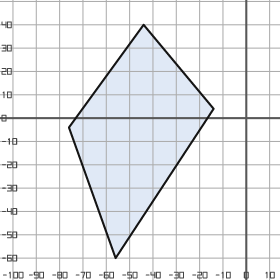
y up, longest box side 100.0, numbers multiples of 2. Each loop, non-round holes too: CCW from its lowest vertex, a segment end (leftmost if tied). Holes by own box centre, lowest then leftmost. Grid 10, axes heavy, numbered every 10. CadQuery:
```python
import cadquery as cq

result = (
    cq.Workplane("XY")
    .moveTo(-56.0, -60.0)
    .lineTo(-14.0, 4.0)
    .lineTo(-44.0, 40.0)
    .lineTo(-76.0, -4.0)
    .close()
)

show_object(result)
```